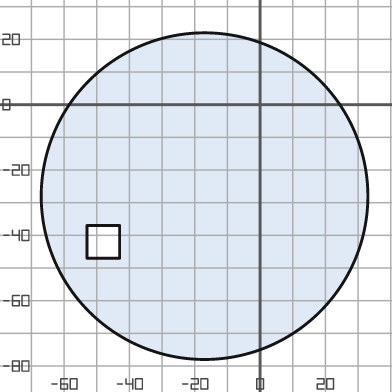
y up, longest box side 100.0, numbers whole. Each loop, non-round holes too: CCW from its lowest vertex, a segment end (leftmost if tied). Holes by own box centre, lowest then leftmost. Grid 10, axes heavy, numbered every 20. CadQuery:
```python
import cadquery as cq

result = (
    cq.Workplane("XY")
    .moveTo(-17.0, -28.0)
    .circle(50.0)
    .moveTo(-53.0, -47.0)
    .lineTo(-43.0, -47.0)
    .lineTo(-43.0, -37.0)
    .lineTo(-53.0, -37.0)
    .close()
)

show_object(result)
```